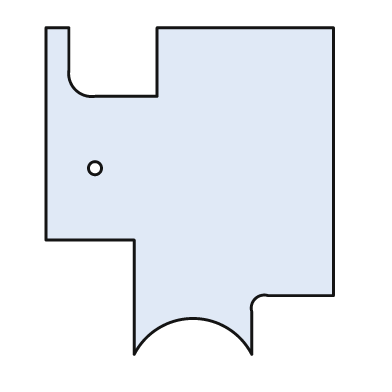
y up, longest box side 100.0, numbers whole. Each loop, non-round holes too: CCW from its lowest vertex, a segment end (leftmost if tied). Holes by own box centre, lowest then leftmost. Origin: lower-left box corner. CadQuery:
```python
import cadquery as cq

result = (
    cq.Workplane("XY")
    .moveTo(27.0, 0.0)
    .threePointArc((45.0, 11.0), (63.0, 0.0))
    .lineTo(63.0, 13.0)
    .threePointArc((64.0, 17.0), (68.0, 18.0))
    .lineTo(88.0, 18.0)
    .lineTo(88.0, 100.0)
    .lineTo(34.0, 100.0)
    .lineTo(34.0, 79.0)
    .lineTo(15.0, 79.0)
    .threePointArc((9.0, 81.0), (7.0, 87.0))
    .lineTo(7.0, 100.0)
    .lineTo(0.0, 100.0)
    .lineTo(0.0, 35.0)
    .lineTo(27.0, 35.0)
    .close()
    .moveTo(15.0, 57.0)
    .circle(2.0)
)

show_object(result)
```